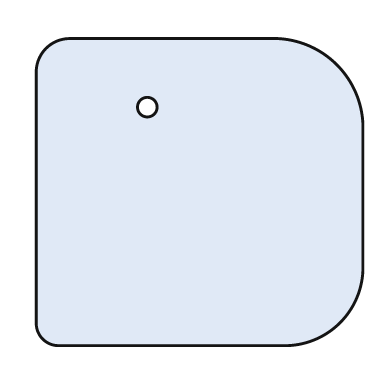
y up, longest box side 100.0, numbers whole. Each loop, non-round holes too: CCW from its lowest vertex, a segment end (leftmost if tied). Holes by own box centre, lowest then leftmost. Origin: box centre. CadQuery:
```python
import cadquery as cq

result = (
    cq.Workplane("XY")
    .moveTo(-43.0, -47.0)
    .lineTo(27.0, -47.0)
    .threePointArc((43.0, -40.0), (50.0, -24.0))
    .lineTo(50.0, 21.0)
    .threePointArc((42.0, 39.0), (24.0, 47.0))
    .lineTo(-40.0, 47.0)
    .threePointArc((-47.0, 44.0), (-50.0, 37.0))
    .lineTo(-50.0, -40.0)
    .threePointArc((-48.0, -45.0), (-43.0, -47.0))
    .close()
    .moveTo(-16.0, 26.0)
    .circle(3.0)
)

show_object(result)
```